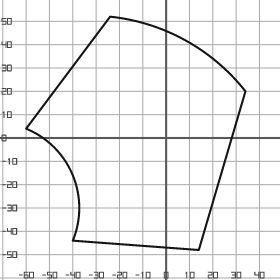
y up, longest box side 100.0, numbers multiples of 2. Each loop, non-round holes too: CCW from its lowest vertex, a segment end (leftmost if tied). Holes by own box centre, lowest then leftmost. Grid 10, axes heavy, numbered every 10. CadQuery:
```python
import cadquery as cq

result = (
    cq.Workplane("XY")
    .moveTo(14.0, -48.0)
    .lineTo(34.0, 20.0)
    .threePointArc((8.0, 42.0), (-24.0, 52.0))
    .lineTo(-60.0, 4.0)
    .threePointArc((-40.0, -16.0), (-40.0, -44.0))
    .close()
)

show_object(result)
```